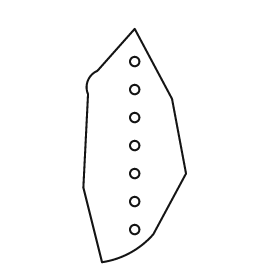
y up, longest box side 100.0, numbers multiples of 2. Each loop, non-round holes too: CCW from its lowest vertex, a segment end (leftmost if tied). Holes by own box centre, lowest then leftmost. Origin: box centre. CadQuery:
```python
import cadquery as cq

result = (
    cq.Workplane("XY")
    .moveTo(-14.0, -50.0)
    .threePointArc((-2.0, -46.0), (8.0, -38.0))
    .lineTo(22.0, -12.0)
    .lineTo(16.0, 20.0)
    .lineTo(0.0, 50.0)
    .lineTo(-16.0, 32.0)
    .threePointArc((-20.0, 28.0), (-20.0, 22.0))
    .lineTo(-22.0, -18.0)
    .close()
    .moveTo(0.0, -36.0)
    .circle(2.0)
    .moveTo(0.0, -24.0)
    .circle(2.0)
    .moveTo(0.0, -12.0)
    .circle(2.0)
    .moveTo(0.0, 0.0)
    .circle(2.0)
    .moveTo(0.0, 12.0)
    .circle(2.0)
    .moveTo(0.0, 24.0)
    .circle(2.0)
    .moveTo(0.0, 36.0)
    .circle(2.0)
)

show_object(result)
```